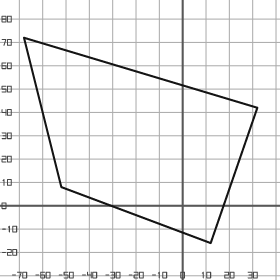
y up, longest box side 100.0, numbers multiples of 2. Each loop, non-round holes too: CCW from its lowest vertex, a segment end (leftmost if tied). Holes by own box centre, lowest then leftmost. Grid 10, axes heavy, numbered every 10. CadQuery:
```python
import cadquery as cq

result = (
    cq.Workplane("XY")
    .moveTo(12.0, -16.0)
    .lineTo(32.0, 42.0)
    .lineTo(-68.0, 72.0)
    .lineTo(-52.0, 8.0)
    .close()
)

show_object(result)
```